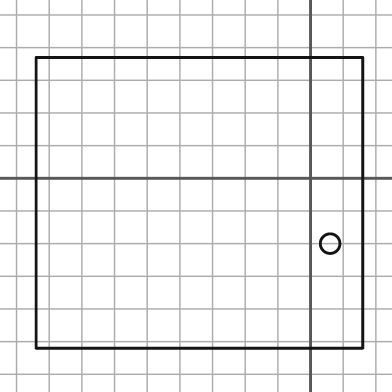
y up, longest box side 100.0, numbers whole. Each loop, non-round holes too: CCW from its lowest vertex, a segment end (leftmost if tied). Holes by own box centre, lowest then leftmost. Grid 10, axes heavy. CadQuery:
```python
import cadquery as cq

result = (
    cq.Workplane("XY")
    .moveTo(-84.0, -52.0)
    .lineTo(16.0, -52.0)
    .lineTo(16.0, 37.0)
    .lineTo(-84.0, 37.0)
    .close()
    .moveTo(6.0, -20.0)
    .circle(3.0)
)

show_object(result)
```